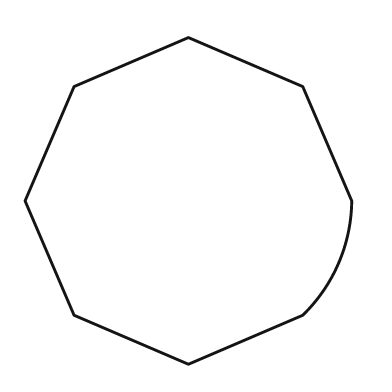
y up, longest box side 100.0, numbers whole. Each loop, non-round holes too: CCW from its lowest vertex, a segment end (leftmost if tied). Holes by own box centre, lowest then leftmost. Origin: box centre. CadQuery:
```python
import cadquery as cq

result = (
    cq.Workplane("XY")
    .moveTo(0.0, -50.0)
    .lineTo(35.0, -35.0)
    .threePointArc((46.0, -19.0), (50.0, 0.0))
    .lineTo(35.0, 35.0)
    .lineTo(0.0, 50.0)
    .lineTo(-35.0, 35.0)
    .lineTo(-50.0, 0.0)
    .lineTo(-35.0, -35.0)
    .close()
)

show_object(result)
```